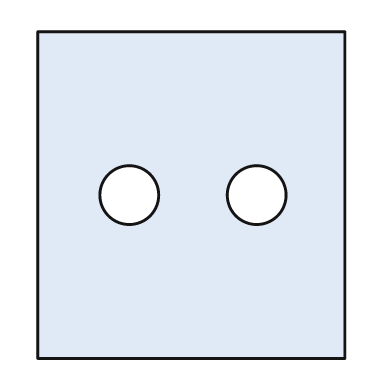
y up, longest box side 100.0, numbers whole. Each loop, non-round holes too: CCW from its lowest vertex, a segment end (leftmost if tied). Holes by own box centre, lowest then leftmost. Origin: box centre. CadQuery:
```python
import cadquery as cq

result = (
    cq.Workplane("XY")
    .moveTo(-47.0, -50.0)
    .lineTo(47.0, -50.0)
    .lineTo(47.0, 50.0)
    .lineTo(-47.0, 50.0)
    .close()
    .moveTo(-19.0, 0.0)
    .circle(9.0)
    .moveTo(20.0, 0.0)
    .circle(9.0)
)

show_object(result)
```